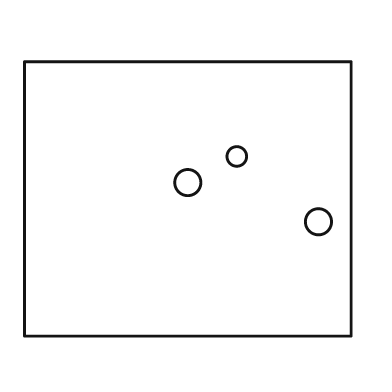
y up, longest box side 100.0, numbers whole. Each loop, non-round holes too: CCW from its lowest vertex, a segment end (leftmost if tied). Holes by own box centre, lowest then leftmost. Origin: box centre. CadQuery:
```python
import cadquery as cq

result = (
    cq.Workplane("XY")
    .moveTo(-50.0, -42.0)
    .lineTo(50.0, -42.0)
    .lineTo(50.0, 42.0)
    .lineTo(-50.0, 42.0)
    .close()
    .moveTo(40.0, -7.0)
    .circle(4.0)
    .moveTo(0.0, 5.0)
    .circle(4.0)
    .moveTo(15.0, 13.0)
    .circle(3.0)
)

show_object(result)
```